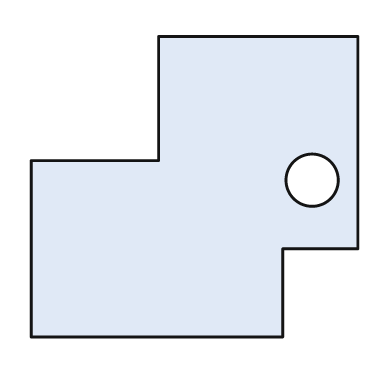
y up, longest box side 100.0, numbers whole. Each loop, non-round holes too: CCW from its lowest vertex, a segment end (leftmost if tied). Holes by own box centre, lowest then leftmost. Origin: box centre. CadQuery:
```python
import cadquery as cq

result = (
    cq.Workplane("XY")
    .moveTo(-50.0, -46.0)
    .lineTo(27.0, -46.0)
    .lineTo(27.0, -19.0)
    .lineTo(50.0, -19.0)
    .lineTo(50.0, 46.0)
    .lineTo(-11.0, 46.0)
    .lineTo(-11.0, 8.0)
    .lineTo(-50.0, 8.0)
    .close()
    .moveTo(36.0, 2.0)
    .circle(8.0)
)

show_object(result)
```